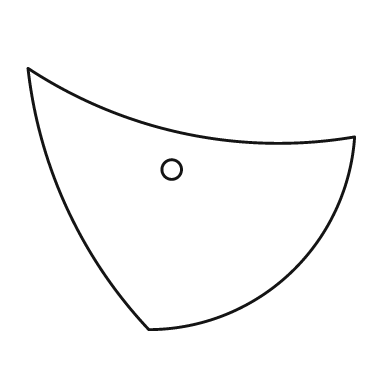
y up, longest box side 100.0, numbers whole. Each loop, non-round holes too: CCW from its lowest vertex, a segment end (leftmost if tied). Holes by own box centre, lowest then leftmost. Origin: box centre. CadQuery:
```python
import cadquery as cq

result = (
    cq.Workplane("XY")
    .moveTo(-13.0, -40.0)
    .threePointArc((30.0, -23.0), (50.0, 19.0))
    .threePointArc((-2.0, 20.0), (-50.0, 40.0))
    .threePointArc((-38.0, -3.0), (-13.0, -40.0))
    .close()
    .moveTo(-6.0, 9.0)
    .circle(3.0)
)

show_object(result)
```